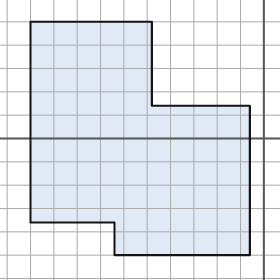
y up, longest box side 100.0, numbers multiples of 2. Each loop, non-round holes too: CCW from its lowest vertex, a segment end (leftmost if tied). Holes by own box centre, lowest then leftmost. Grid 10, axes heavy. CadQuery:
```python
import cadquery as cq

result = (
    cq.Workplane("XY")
    .moveTo(-64.0, -50.0)
    .lineTo(-6.0, -50.0)
    .lineTo(-6.0, 14.0)
    .lineTo(-48.0, 14.0)
    .lineTo(-48.0, 50.0)
    .lineTo(-100.0, 50.0)
    .lineTo(-100.0, -36.0)
    .lineTo(-64.0, -36.0)
    .close()
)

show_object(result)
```